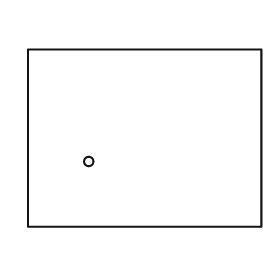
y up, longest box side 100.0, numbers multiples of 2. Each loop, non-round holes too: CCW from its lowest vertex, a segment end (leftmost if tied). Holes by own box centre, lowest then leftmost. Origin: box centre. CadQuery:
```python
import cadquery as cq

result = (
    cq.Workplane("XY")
    .moveTo(-50.0, -38.0)
    .lineTo(50.0, -38.0)
    .lineTo(50.0, 38.0)
    .lineTo(-50.0, 38.0)
    .close()
    .moveTo(-24.0, -10.0)
    .circle(2.0)
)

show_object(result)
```